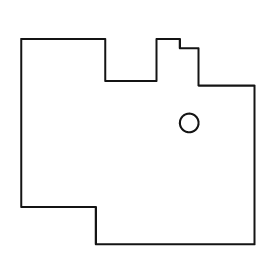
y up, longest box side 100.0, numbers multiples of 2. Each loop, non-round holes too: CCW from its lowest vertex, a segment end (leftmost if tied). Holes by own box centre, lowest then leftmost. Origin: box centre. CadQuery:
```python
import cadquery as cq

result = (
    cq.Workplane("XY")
    .moveTo(-18.0, -44.0)
    .lineTo(50.0, -44.0)
    .lineTo(50.0, 24.0)
    .lineTo(26.0, 24.0)
    .lineTo(26.0, 40.0)
    .lineTo(18.0, 40.0)
    .lineTo(18.0, 44.0)
    .lineTo(8.0, 44.0)
    .lineTo(8.0, 26.0)
    .lineTo(-14.0, 26.0)
    .lineTo(-14.0, 44.0)
    .lineTo(-50.0, 44.0)
    .lineTo(-50.0, -28.0)
    .lineTo(-18.0, -28.0)
    .close()
    .moveTo(22.0, 8.0)
    .circle(4.0)
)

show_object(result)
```